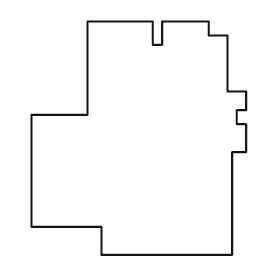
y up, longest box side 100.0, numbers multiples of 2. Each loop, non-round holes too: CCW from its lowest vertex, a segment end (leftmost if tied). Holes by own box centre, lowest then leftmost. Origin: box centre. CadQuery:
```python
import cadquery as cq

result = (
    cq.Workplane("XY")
    .moveTo(-16.0, -50.0)
    .lineTo(40.0, -50.0)
    .lineTo(40.0, -6.0)
    .lineTo(46.0, -6.0)
    .lineTo(46.0, 6.0)
    .lineTo(42.0, 6.0)
    .lineTo(42.0, 12.0)
    .lineTo(46.0, 12.0)
    .lineTo(46.0, 20.0)
    .lineTo(38.0, 20.0)
    .lineTo(38.0, 44.0)
    .lineTo(30.0, 44.0)
    .lineTo(30.0, 50.0)
    .lineTo(10.0, 50.0)
    .lineTo(10.0, 40.0)
    .lineTo(6.0, 40.0)
    .lineTo(6.0, 50.0)
    .lineTo(-22.0, 50.0)
    .lineTo(-22.0, 10.0)
    .lineTo(-46.0, 10.0)
    .lineTo(-46.0, -38.0)
    .lineTo(-16.0, -38.0)
    .close()
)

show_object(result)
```